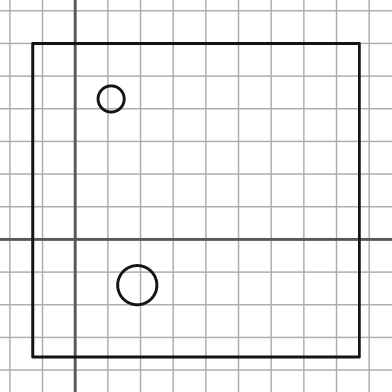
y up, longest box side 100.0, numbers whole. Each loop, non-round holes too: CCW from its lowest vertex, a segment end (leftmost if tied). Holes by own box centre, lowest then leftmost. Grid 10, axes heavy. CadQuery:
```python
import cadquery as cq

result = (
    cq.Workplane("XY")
    .moveTo(-13.0, -36.0)
    .lineTo(87.0, -36.0)
    .lineTo(87.0, 60.0)
    .lineTo(-13.0, 60.0)
    .close()
    .moveTo(19.0, -14.0)
    .circle(6.0)
    .moveTo(11.0, 43.0)
    .circle(4.0)
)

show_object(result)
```